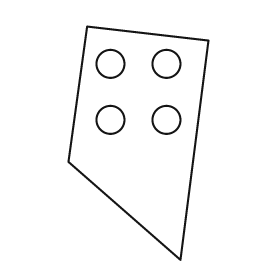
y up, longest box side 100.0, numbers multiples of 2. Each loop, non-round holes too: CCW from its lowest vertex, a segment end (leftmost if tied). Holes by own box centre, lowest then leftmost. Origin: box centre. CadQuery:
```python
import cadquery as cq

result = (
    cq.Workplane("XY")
    .moveTo(18.0, -50.0)
    .lineTo(30.0, 44.0)
    .lineTo(-22.0, 50.0)
    .lineTo(-30.0, -8.0)
    .close()
    .moveTo(-12.0, 10.0)
    .circle(6.0)
    .moveTo(12.0, 10.0)
    .circle(6.0)
    .moveTo(-12.0, 34.0)
    .circle(6.0)
    .moveTo(12.0, 34.0)
    .circle(6.0)
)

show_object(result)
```